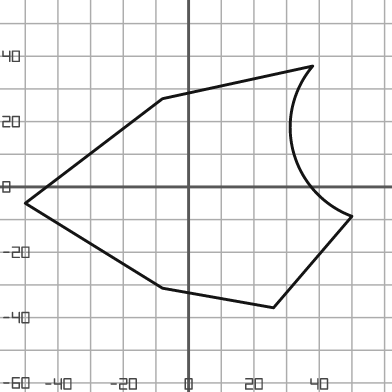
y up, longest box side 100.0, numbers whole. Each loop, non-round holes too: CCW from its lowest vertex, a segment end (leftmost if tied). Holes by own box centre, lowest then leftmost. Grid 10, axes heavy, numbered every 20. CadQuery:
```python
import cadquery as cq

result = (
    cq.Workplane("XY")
    .moveTo(26.0, -37.0)
    .lineTo(50.0, -9.0)
    .threePointArc((32.0, 11.0), (38.0, 37.0))
    .lineTo(-8.0, 27.0)
    .lineTo(-50.0, -5.0)
    .lineTo(-8.0, -31.0)
    .close()
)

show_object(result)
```